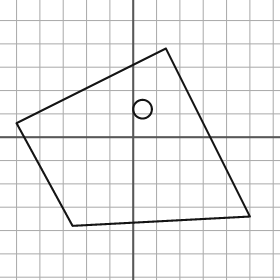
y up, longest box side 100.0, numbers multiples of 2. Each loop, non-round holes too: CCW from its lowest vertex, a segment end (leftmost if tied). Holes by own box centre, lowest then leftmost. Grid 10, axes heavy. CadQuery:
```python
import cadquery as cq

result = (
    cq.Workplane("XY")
    .moveTo(-26.0, -38.0)
    .lineTo(50.0, -34.0)
    .lineTo(14.0, 38.0)
    .lineTo(-50.0, 6.0)
    .close()
    .moveTo(4.0, 12.0)
    .circle(4.0)
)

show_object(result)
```